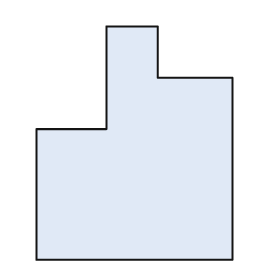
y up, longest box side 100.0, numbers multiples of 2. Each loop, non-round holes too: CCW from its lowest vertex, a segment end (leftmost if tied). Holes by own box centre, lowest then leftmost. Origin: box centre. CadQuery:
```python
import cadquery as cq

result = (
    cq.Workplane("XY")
    .moveTo(-42.0, -50.0)
    .lineTo(42.0, -50.0)
    .lineTo(42.0, 28.0)
    .lineTo(10.0, 28.0)
    .lineTo(10.0, 50.0)
    .lineTo(-12.0, 50.0)
    .lineTo(-12.0, 6.0)
    .lineTo(-42.0, 6.0)
    .close()
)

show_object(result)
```